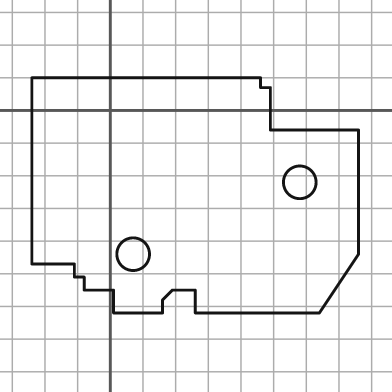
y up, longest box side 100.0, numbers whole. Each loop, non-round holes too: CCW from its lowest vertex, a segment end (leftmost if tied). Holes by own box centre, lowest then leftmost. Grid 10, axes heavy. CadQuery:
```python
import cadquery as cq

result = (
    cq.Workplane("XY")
    .moveTo(1.0, -62.0)
    .lineTo(16.0, -62.0)
    .lineTo(16.0, -58.0)
    .lineTo(19.0, -55.0)
    .lineTo(26.0, -55.0)
    .lineTo(26.0, -62.0)
    .lineTo(64.0, -62.0)
    .lineTo(76.0, -44.0)
    .lineTo(76.0, -6.0)
    .lineTo(49.0, -6.0)
    .lineTo(49.0, 7.0)
    .lineTo(46.0, 7.0)
    .lineTo(46.0, 10.0)
    .lineTo(-24.0, 10.0)
    .lineTo(-24.0, -47.0)
    .lineTo(-11.0, -47.0)
    .lineTo(-11.0, -51.0)
    .lineTo(-8.0, -51.0)
    .lineTo(-8.0, -55.0)
    .lineTo(1.0, -55.0)
    .close()
    .moveTo(7.0, -44.0)
    .circle(5.0)
    .moveTo(58.0, -22.0)
    .circle(5.0)
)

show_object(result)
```